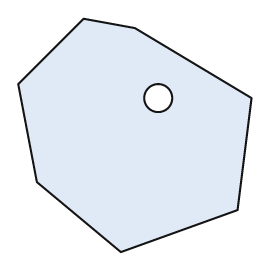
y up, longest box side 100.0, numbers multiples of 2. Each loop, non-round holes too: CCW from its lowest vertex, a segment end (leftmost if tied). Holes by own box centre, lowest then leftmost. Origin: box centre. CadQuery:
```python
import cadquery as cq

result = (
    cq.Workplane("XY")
    .moveTo(-6.0, -50.0)
    .lineTo(44.0, -32.0)
    .lineTo(50.0, 16.0)
    .lineTo(0.0, 46.0)
    .lineTo(-22.0, 50.0)
    .lineTo(-50.0, 22.0)
    .lineTo(-42.0, -20.0)
    .close()
    .moveTo(10.0, 16.0)
    .circle(6.0)
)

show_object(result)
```